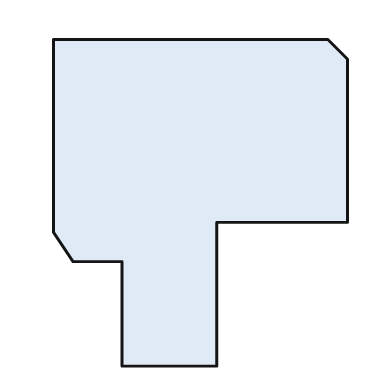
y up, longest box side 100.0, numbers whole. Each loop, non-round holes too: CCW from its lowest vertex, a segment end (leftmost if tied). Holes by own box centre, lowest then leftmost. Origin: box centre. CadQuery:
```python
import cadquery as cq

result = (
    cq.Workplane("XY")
    .moveTo(-24.0, -50.0)
    .lineTo(5.0, -50.0)
    .lineTo(5.0, -6.0)
    .lineTo(45.0, -6.0)
    .lineTo(45.0, 44.0)
    .lineTo(39.0, 50.0)
    .lineTo(-45.0, 50.0)
    .lineTo(-45.0, -9.0)
    .lineTo(-39.0, -18.0)
    .lineTo(-24.0, -18.0)
    .close()
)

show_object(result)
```